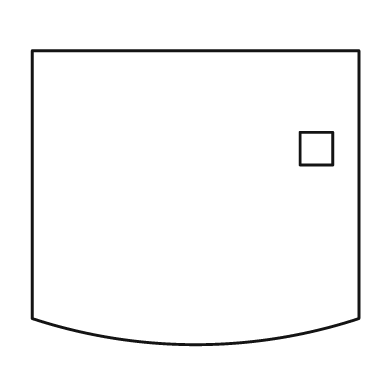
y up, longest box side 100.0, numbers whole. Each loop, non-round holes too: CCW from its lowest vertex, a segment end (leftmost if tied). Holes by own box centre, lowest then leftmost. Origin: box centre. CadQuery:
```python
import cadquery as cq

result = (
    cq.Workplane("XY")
    .moveTo(-50.0, -37.0)
    .threePointArc((0.0, -45.0), (50.0, -37.0))
    .lineTo(50.0, 45.0)
    .lineTo(-50.0, 45.0)
    .close()
    .moveTo(32.0, 10.0)
    .lineTo(42.0, 10.0)
    .lineTo(42.0, 20.0)
    .lineTo(32.0, 20.0)
    .close()
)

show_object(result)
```